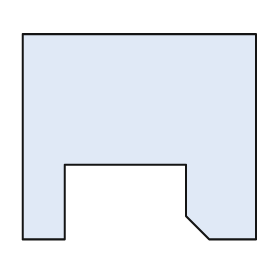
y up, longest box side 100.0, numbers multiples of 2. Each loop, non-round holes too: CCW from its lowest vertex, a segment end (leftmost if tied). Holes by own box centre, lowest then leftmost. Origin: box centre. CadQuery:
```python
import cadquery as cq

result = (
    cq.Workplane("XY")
    .moveTo(-50.0, -44.0)
    .lineTo(-32.0, -44.0)
    .lineTo(-32.0, -12.0)
    .lineTo(20.0, -12.0)
    .lineTo(20.0, -34.0)
    .lineTo(30.0, -44.0)
    .lineTo(50.0, -44.0)
    .lineTo(50.0, 44.0)
    .lineTo(-50.0, 44.0)
    .close()
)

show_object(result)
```